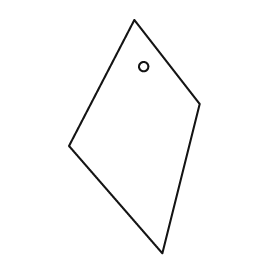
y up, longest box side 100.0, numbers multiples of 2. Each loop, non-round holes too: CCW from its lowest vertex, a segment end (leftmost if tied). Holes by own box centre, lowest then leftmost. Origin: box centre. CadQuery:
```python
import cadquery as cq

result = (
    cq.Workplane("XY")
    .moveTo(12.0, -50.0)
    .lineTo(28.0, 14.0)
    .lineTo(0.0, 50.0)
    .lineTo(-28.0, -4.0)
    .close()
    .moveTo(4.0, 30.0)
    .circle(2.0)
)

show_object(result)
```